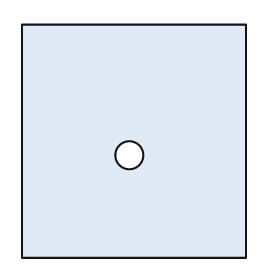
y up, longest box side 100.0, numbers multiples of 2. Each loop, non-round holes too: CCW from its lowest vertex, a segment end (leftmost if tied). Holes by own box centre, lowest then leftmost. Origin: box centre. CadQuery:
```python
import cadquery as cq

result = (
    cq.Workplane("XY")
    .moveTo(-48.0, -50.0)
    .lineTo(48.0, -50.0)
    .lineTo(48.0, 50.0)
    .lineTo(-48.0, 50.0)
    .close()
    .moveTo(-2.0, -6.0)
    .circle(6.0)
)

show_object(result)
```